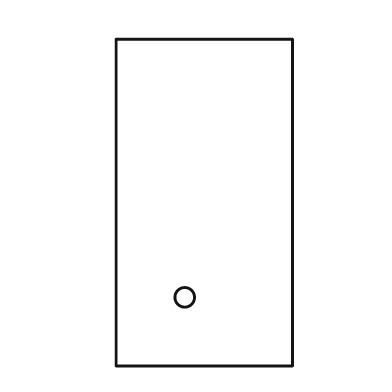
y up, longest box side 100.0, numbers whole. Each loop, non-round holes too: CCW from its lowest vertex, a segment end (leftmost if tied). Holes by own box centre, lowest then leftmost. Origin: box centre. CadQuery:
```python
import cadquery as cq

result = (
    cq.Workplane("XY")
    .moveTo(-27.0, -50.0)
    .lineTo(27.0, -50.0)
    .lineTo(27.0, 50.0)
    .lineTo(-27.0, 50.0)
    .close()
    .moveTo(-6.0, -29.0)
    .circle(3.0)
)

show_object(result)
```